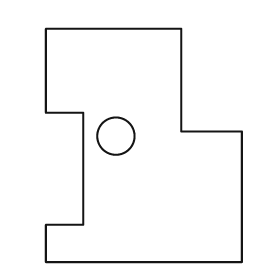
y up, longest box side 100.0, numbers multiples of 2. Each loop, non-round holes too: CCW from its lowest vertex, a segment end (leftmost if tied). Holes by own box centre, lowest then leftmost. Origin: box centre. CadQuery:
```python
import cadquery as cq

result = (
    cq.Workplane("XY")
    .moveTo(-42.0, -50.0)
    .lineTo(42.0, -50.0)
    .lineTo(42.0, 6.0)
    .lineTo(16.0, 6.0)
    .lineTo(16.0, 50.0)
    .lineTo(-42.0, 50.0)
    .lineTo(-42.0, 14.0)
    .lineTo(-26.0, 14.0)
    .lineTo(-26.0, -34.0)
    .lineTo(-42.0, -34.0)
    .close()
    .moveTo(-12.0, 4.0)
    .circle(8.0)
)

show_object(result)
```